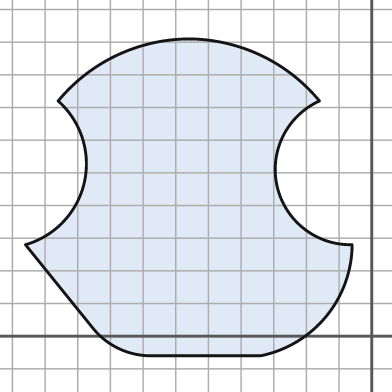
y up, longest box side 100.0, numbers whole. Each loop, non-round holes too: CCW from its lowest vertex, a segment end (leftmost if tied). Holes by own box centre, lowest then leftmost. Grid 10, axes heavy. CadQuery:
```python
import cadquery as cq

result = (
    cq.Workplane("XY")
    .moveTo(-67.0, -6.0)
    .lineTo(-34.0, -6.0)
    .threePointArc((-14.0, 6.0), (-6.0, 28.0))
    .threePointArc((-29.0, 46.0), (-16.0, 72.0))
    .threePointArc((-34.0, 86.0), (-56.0, 91.0))
    .threePointArc((-78.0, 86.0), (-96.0, 72.0))
    .threePointArc((-88.0, 47.0), (-106.0, 28.0))
    .lineTo(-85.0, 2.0)
    .threePointArc((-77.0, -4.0), (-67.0, -6.0))
    .close()
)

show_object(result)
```